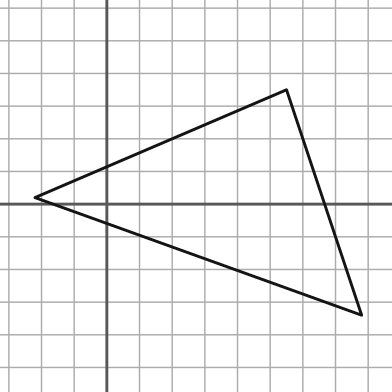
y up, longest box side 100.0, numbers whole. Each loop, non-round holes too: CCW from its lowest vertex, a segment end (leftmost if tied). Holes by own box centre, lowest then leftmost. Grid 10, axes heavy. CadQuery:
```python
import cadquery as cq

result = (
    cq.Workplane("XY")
    .moveTo(78.0, -34.0)
    .lineTo(55.0, 35.0)
    .lineTo(-22.0, 2.0)
    .close()
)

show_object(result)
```